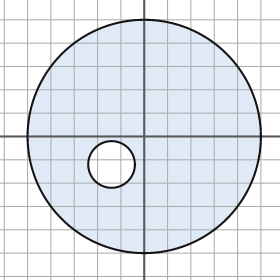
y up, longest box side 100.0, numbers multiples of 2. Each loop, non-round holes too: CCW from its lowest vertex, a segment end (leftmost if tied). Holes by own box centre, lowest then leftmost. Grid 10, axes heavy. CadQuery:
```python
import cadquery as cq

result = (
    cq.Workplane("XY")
    .moveTo(0.0, 0.0)
    .circle(50.0)
    .moveTo(-14.0, -12.0)
    .circle(10.0)
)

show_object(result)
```